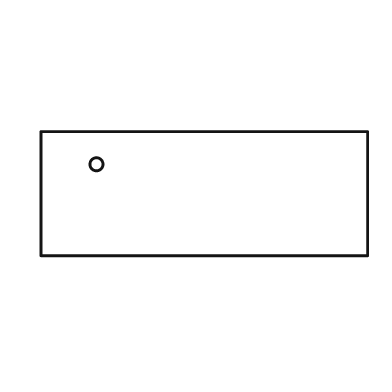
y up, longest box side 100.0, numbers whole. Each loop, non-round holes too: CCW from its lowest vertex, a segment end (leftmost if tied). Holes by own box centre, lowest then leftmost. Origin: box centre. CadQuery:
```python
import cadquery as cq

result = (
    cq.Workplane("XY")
    .moveTo(-50.0, -19.0)
    .lineTo(50.0, -19.0)
    .lineTo(50.0, 19.0)
    .lineTo(-50.0, 19.0)
    .close()
    .moveTo(-33.0, 9.0)
    .circle(2.0)
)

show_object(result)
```